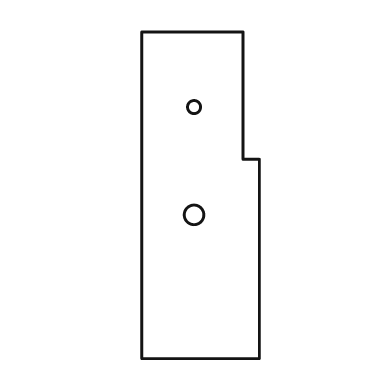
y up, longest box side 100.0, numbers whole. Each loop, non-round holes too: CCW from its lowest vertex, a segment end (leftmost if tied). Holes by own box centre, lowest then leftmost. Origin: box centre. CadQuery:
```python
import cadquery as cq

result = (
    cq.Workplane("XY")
    .moveTo(-18.0, -50.0)
    .lineTo(18.0, -50.0)
    .lineTo(18.0, 11.0)
    .lineTo(13.0, 11.0)
    .lineTo(13.0, 50.0)
    .lineTo(-18.0, 50.0)
    .close()
    .moveTo(-2.0, -6.0)
    .circle(3.0)
    .moveTo(-2.0, 27.0)
    .circle(2.0)
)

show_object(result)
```